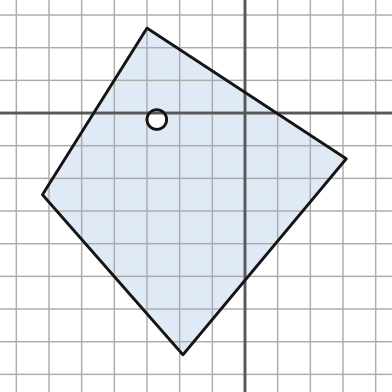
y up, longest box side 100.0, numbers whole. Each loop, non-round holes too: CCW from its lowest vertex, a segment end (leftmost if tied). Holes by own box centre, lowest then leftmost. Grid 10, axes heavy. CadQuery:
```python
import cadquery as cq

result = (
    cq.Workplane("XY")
    .moveTo(-19.0, -74.0)
    .lineTo(31.0, -14.0)
    .lineTo(-30.0, 26.0)
    .lineTo(-62.0, -25.0)
    .close()
    .moveTo(-27.0, -2.0)
    .circle(3.0)
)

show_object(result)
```